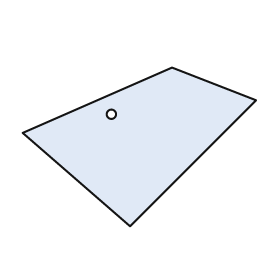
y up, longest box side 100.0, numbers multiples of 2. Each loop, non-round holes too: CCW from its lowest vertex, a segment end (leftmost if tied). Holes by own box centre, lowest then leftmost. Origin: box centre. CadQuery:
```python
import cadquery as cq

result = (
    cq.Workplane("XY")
    .moveTo(-4.0, -34.0)
    .lineTo(50.0, 20.0)
    .lineTo(14.0, 34.0)
    .lineTo(-50.0, 6.0)
    .close()
    .moveTo(-12.0, 14.0)
    .circle(2.0)
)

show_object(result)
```